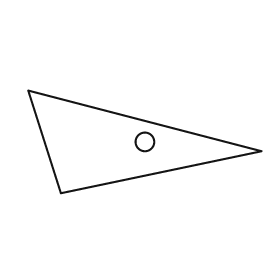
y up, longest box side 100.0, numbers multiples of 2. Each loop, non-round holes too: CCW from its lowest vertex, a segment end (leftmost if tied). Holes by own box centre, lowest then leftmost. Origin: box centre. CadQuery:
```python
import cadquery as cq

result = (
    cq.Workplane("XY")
    .moveTo(-36.0, -22.0)
    .lineTo(50.0, -4.0)
    .lineTo(-50.0, 22.0)
    .close()
    .moveTo(0.0, 0.0)
    .circle(4.0)
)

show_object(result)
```